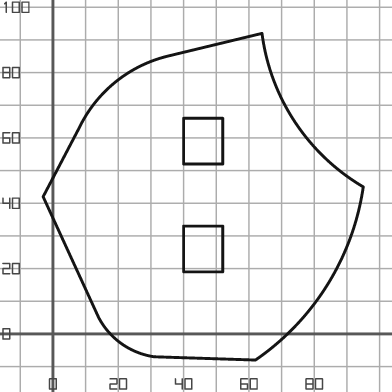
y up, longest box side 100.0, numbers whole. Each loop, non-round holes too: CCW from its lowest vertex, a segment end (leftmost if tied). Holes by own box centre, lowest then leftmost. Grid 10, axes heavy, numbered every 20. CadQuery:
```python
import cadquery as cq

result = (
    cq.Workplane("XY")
    .moveTo(62.0, -8.0)
    .threePointArc((84.0, 15.0), (95.0, 45.0))
    .threePointArc((74.0, 65.0), (64.0, 92.0))
    .lineTo(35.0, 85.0)
    .threePointArc((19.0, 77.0), (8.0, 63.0))
    .lineTo(-3.0, 42.0)
    .lineTo(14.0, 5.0)
    .threePointArc((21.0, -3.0), (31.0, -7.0))
    .close()
    .moveTo(40.0, 19.0)
    .lineTo(52.0, 19.0)
    .lineTo(52.0, 33.0)
    .lineTo(40.0, 33.0)
    .close()
    .moveTo(40.0, 52.0)
    .lineTo(52.0, 52.0)
    .lineTo(52.0, 66.0)
    .lineTo(40.0, 66.0)
    .close()
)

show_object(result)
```